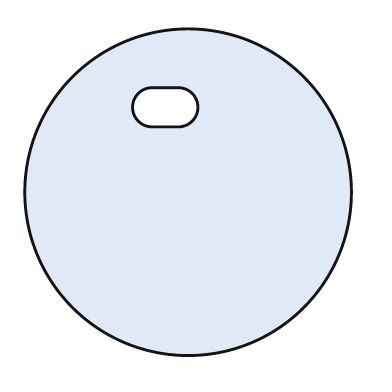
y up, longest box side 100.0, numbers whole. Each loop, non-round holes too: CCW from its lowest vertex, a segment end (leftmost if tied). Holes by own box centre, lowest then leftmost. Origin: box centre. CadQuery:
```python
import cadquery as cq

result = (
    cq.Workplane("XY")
    .moveTo(0.0, 0.0)
    .circle(50.0)
    .moveTo(-11.0, 20.0)
    .lineTo(-3.0, 20.0)
    .threePointArc((3.0, 26.0), (-3.0, 32.0))
    .lineTo(-11.0, 32.0)
    .threePointArc((-17.0, 26.0), (-11.0, 20.0))
    .close()
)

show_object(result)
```